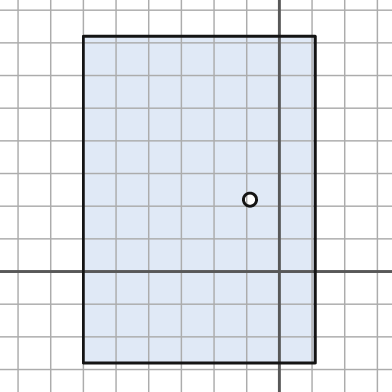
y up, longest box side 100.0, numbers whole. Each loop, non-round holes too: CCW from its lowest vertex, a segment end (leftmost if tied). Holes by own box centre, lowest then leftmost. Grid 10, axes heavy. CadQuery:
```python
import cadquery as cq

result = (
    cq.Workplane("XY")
    .moveTo(-60.0, -28.0)
    .lineTo(11.0, -28.0)
    .lineTo(11.0, 72.0)
    .lineTo(-60.0, 72.0)
    .close()
    .moveTo(-9.0, 22.0)
    .circle(2.0)
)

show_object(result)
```